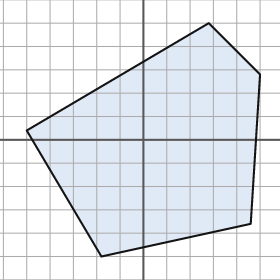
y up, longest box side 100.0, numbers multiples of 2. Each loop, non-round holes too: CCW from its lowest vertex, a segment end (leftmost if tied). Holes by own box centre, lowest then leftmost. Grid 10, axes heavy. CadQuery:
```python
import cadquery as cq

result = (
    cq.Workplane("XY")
    .moveTo(-18.0, -50.0)
    .lineTo(46.0, -36.0)
    .lineTo(50.0, 28.0)
    .lineTo(28.0, 50.0)
    .lineTo(-50.0, 4.0)
    .close()
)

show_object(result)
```